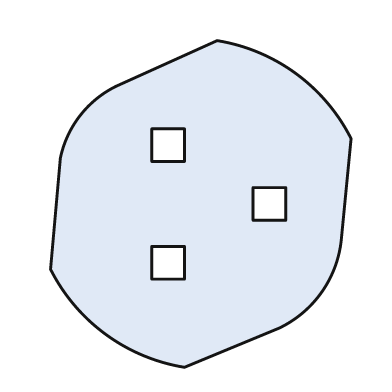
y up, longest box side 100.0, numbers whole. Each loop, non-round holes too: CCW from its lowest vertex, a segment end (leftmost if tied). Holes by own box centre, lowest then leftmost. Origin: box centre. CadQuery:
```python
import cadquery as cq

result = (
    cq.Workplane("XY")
    .moveTo(-5.0, -50.0)
    .lineTo(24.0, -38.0)
    .threePointArc((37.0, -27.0), (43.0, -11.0))
    .lineTo(46.0, 20.0)
    .threePointArc((29.0, 40.0), (5.0, 50.0))
    .lineTo(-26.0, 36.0)
    .threePointArc((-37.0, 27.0), (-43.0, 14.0))
    .lineTo(-46.0, -20.0)
    .threePointArc((-29.0, -40.0), (-5.0, -50.0))
    .close()
    .moveTo(-15.0, -23.0)
    .lineTo(-5.0, -23.0)
    .lineTo(-5.0, -13.0)
    .lineTo(-15.0, -13.0)
    .close()
    .moveTo(16.0, -5.0)
    .lineTo(26.0, -5.0)
    .lineTo(26.0, 5.0)
    .lineTo(16.0, 5.0)
    .close()
    .moveTo(-15.0, 13.0)
    .lineTo(-5.0, 13.0)
    .lineTo(-5.0, 23.0)
    .lineTo(-15.0, 23.0)
    .close()
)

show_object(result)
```